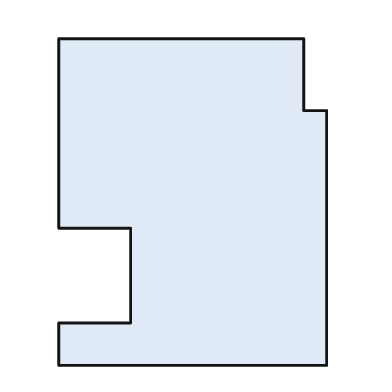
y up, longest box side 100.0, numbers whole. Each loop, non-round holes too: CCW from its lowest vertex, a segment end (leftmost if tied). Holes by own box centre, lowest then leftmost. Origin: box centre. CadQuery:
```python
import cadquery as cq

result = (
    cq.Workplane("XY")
    .moveTo(-41.0, -50.0)
    .lineTo(41.0, -50.0)
    .lineTo(41.0, 28.0)
    .lineTo(34.0, 28.0)
    .lineTo(34.0, 50.0)
    .lineTo(-41.0, 50.0)
    .lineTo(-41.0, -8.0)
    .lineTo(-19.0, -8.0)
    .lineTo(-19.0, -37.0)
    .lineTo(-41.0, -37.0)
    .close()
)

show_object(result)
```